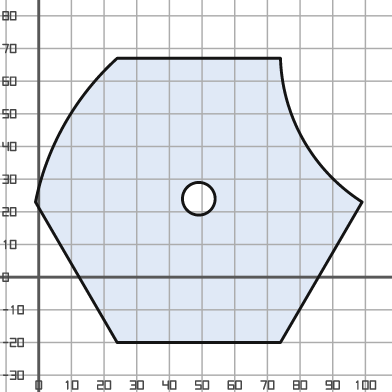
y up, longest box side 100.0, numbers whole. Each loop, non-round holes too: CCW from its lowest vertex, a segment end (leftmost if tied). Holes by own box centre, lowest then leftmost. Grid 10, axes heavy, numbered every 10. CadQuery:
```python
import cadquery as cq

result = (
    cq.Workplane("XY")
    .moveTo(24.0, -20.0)
    .lineTo(74.0, -20.0)
    .lineTo(99.0, 23.0)
    .threePointArc((81.0, 42.0), (74.0, 67.0))
    .lineTo(24.0, 67.0)
    .threePointArc((8.0, 47.0), (-1.0, 23.0))
    .close()
    .moveTo(49.0, 24.0)
    .circle(5.0)
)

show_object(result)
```